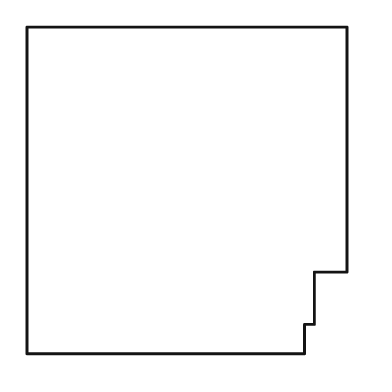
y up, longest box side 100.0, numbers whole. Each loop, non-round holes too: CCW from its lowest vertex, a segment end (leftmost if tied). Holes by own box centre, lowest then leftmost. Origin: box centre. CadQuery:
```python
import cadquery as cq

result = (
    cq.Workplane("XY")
    .moveTo(-49.0, -50.0)
    .lineTo(36.0, -50.0)
    .lineTo(36.0, -41.0)
    .lineTo(39.0, -41.0)
    .lineTo(39.0, -25.0)
    .lineTo(49.0, -25.0)
    .lineTo(49.0, 50.0)
    .lineTo(-49.0, 50.0)
    .close()
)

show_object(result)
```